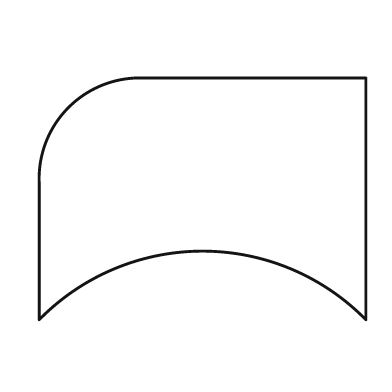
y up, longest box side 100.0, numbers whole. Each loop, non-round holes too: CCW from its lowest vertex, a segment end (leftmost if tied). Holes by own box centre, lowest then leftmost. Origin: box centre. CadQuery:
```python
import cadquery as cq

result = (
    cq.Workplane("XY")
    .moveTo(-50.0, -37.0)
    .threePointArc((0.0, -16.0), (50.0, -37.0))
    .lineTo(50.0, 37.0)
    .lineTo(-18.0, 37.0)
    .threePointArc((-41.0, 28.0), (-50.0, 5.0))
    .close()
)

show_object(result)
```